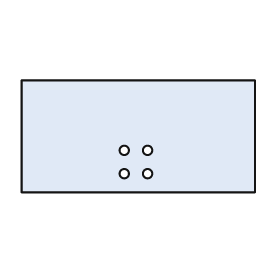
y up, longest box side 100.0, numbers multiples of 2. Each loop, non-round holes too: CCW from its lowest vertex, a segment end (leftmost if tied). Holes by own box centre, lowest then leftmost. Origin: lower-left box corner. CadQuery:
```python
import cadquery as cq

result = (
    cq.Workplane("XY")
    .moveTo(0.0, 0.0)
    .lineTo(100.0, 0.0)
    .lineTo(100.0, 48.0)
    .lineTo(0.0, 48.0)
    .close()
    .moveTo(44.0, 8.0)
    .circle(2.0)
    .moveTo(54.0, 8.0)
    .circle(2.0)
    .moveTo(44.0, 18.0)
    .circle(2.0)
    .moveTo(54.0, 18.0)
    .circle(2.0)
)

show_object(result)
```